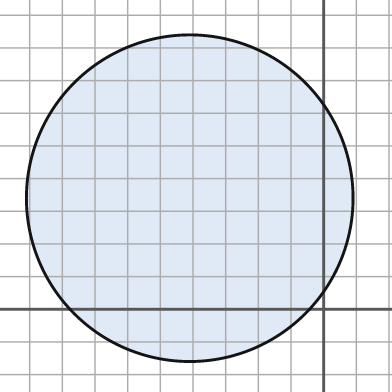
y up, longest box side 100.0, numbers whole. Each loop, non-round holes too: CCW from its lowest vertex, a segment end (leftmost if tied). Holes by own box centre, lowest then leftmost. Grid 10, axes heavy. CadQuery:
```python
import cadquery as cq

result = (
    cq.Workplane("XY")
    .moveTo(-41.0, 34.0)
    .circle(50.0)
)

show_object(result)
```